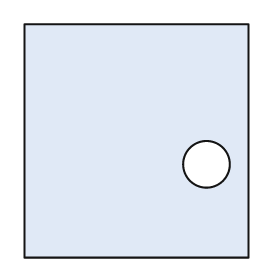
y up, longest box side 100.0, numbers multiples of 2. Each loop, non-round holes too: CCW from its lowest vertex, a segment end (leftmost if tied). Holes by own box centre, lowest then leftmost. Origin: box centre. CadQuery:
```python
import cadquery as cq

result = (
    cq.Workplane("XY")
    .moveTo(-48.0, -50.0)
    .lineTo(48.0, -50.0)
    .lineTo(48.0, 50.0)
    .lineTo(-48.0, 50.0)
    .close()
    .moveTo(30.0, -10.0)
    .circle(10.0)
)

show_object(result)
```